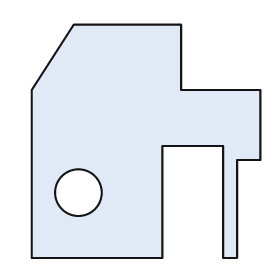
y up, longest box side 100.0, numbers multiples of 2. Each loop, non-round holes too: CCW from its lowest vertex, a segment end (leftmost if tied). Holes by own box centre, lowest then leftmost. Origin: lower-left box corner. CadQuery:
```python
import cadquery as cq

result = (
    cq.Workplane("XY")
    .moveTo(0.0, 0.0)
    .lineTo(56.0, 0.0)
    .lineTo(56.0, 48.0)
    .lineTo(82.0, 48.0)
    .lineTo(82.0, 0.0)
    .lineTo(88.0, 0.0)
    .lineTo(88.0, 42.0)
    .lineTo(98.0, 42.0)
    .lineTo(98.0, 72.0)
    .lineTo(64.0, 72.0)
    .lineTo(64.0, 100.0)
    .lineTo(18.0, 100.0)
    .lineTo(0.0, 72.0)
    .close()
    .moveTo(20.0, 28.0)
    .circle(10.0)
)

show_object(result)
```